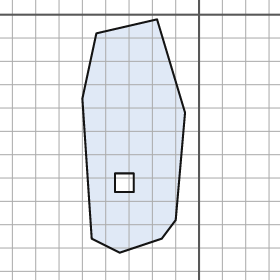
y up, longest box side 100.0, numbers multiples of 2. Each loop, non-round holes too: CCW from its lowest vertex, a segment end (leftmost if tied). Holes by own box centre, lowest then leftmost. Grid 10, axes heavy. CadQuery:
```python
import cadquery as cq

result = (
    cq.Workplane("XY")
    .moveTo(-34.0, -102.0)
    .lineTo(-16.0, -96.0)
    .lineTo(-10.0, -88.0)
    .lineTo(-6.0, -42.0)
    .lineTo(-18.0, -2.0)
    .lineTo(-44.0, -8.0)
    .lineTo(-50.0, -36.0)
    .lineTo(-46.0, -96.0)
    .close()
    .moveTo(-36.0, -76.0)
    .lineTo(-28.0, -76.0)
    .lineTo(-28.0, -68.0)
    .lineTo(-36.0, -68.0)
    .close()
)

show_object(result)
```